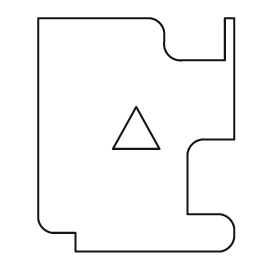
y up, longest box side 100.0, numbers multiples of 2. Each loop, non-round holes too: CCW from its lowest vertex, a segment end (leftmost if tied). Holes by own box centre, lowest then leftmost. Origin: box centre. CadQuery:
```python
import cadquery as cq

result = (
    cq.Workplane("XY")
    .moveTo(-26.0, -50.0)
    .lineTo(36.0, -50.0)
    .threePointArc((40.0, -48.0), (42.0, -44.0))
    .lineTo(42.0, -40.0)
    .threePointArc((40.0, -36.0), (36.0, -34.0))
    .lineTo(22.0, -34.0)
    .lineTo(22.0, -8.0)
    .threePointArc((24.0, -4.0), (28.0, -2.0))
    .lineTo(42.0, -2.0)
    .lineTo(42.0, 50.0)
    .lineTo(38.0, 50.0)
    .lineTo(38.0, 32.0)
    .lineTo(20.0, 32.0)
    .threePointArc((14.0, 34.0), (12.0, 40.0))
    .lineTo(12.0, 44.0)
    .threePointArc((10.0, 48.0), (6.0, 50.0))
    .lineTo(-42.0, 50.0)
    .lineTo(-42.0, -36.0)
    .threePointArc((-40.0, -40.0), (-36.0, -42.0))
    .lineTo(-26.0, -42.0)
    .close()
    .moveTo(-10.0, -6.0)
    .lineTo(10.0, -6.0)
    .lineTo(0.0, 12.0)
    .close()
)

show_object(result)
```